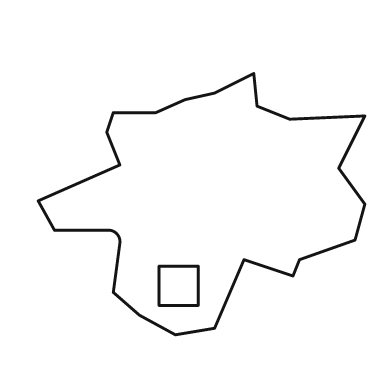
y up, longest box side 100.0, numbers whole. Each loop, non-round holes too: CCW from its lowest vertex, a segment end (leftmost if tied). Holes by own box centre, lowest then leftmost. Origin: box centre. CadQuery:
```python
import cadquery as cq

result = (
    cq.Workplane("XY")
    .moveTo(-8.0, -40.0)
    .lineTo(4.0, -38.0)
    .lineTo(13.0, -17.0)
    .lineTo(28.0, -22.0)
    .lineTo(30.0, -17.0)
    .lineTo(47.0, -11.0)
    .lineTo(50.0, 0.0)
    .lineTo(42.0, 11.0)
    .lineTo(50.0, 27.0)
    .lineTo(27.0, 26.0)
    .lineTo(17.0, 30.0)
    .lineTo(16.0, 40.0)
    .lineTo(4.0, 34.0)
    .lineTo(-5.0, 32.0)
    .lineTo(-14.0, 28.0)
    .lineTo(-27.0, 28.0)
    .lineTo(-29.0, 22.0)
    .lineTo(-25.0, 12.0)
    .lineTo(-50.0, 1.0)
    .lineTo(-45.0, -8.0)
    .lineTo(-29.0, -8.0)
    .threePointArc((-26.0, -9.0), (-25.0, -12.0))
    .lineTo(-27.0, -27.0)
    .lineTo(-19.0, -34.0)
    .close()
    .moveTo(-13.0, -31.0)
    .lineTo(-1.0, -31.0)
    .lineTo(-1.0, -19.0)
    .lineTo(-13.0, -19.0)
    .close()
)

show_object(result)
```